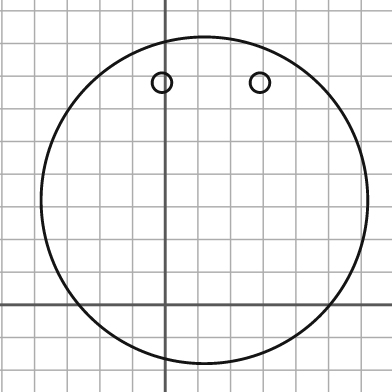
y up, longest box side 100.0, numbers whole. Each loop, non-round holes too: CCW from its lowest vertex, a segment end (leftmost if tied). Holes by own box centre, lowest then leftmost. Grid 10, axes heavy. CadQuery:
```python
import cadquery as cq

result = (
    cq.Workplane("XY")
    .moveTo(12.0, 32.0)
    .circle(50.0)
    .moveTo(-1.0, 68.0)
    .circle(3.0)
    .moveTo(29.0, 68.0)
    .circle(3.0)
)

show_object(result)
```